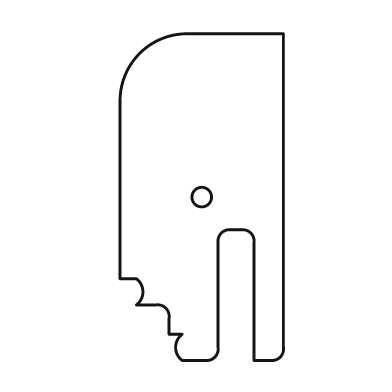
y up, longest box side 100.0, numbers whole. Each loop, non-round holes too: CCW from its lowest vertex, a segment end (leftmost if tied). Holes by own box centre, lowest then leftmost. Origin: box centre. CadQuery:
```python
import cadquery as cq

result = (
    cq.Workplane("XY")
    .moveTo(-6.0, -50.0)
    .lineTo(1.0, -50.0)
    .threePointArc((4.0, -49.0), (5.0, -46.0))
    .lineTo(5.0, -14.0)
    .threePointArc((6.0, -11.0), (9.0, -10.0))
    .lineTo(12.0, -10.0)
    .threePointArc((15.0, -11.0), (16.0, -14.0))
    .lineTo(16.0, -50.0)
    .lineTo(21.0, -50.0)
    .threePointArc((24.0, -49.0), (25.0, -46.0))
    .lineTo(25.0, 50.0)
    .lineTo(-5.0, 50.0)
    .threePointArc((-19.0, 44.0), (-25.0, 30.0))
    .lineTo(-25.0, -25.0)
    .lineTo(-20.0, -25.0)
    .threePointArc((-18.0, -29.0), (-20.0, -33.0))
    .lineTo(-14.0, -33.0)
    .threePointArc((-11.0, -34.0), (-10.0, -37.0))
    .lineTo(-10.0, -42.0)
    .lineTo(-6.0, -42.0)
    .threePointArc((-8.0, -46.0), (-6.0, -50.0))
    .close()
    .moveTo(0.0, 0.0)
    .circle(3.0)
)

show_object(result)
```